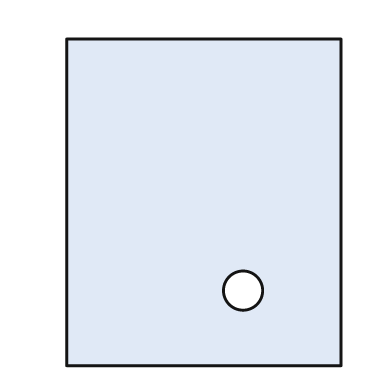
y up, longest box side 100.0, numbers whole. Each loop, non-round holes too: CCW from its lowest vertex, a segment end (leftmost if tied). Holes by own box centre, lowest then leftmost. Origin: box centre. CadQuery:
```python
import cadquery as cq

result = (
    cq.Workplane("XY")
    .moveTo(-42.0, -50.0)
    .lineTo(42.0, -50.0)
    .lineTo(42.0, 50.0)
    .lineTo(-42.0, 50.0)
    .close()
    .moveTo(12.0, -27.0)
    .circle(6.0)
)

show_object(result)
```